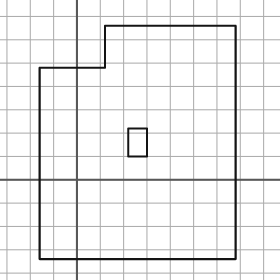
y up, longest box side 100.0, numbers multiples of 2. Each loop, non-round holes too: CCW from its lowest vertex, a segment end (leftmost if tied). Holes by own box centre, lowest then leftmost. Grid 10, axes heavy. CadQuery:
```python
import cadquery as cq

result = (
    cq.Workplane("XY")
    .moveTo(-16.0, -34.0)
    .lineTo(68.0, -34.0)
    .lineTo(68.0, 66.0)
    .lineTo(12.0, 66.0)
    .lineTo(12.0, 48.0)
    .lineTo(-16.0, 48.0)
    .close()
    .moveTo(22.0, 10.0)
    .lineTo(30.0, 10.0)
    .lineTo(30.0, 22.0)
    .lineTo(22.0, 22.0)
    .close()
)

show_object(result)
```